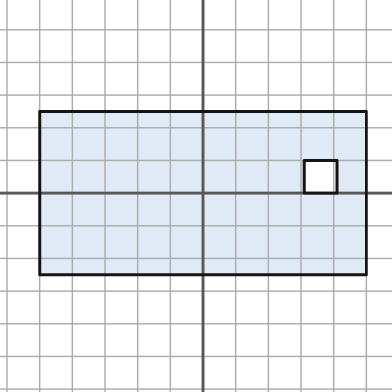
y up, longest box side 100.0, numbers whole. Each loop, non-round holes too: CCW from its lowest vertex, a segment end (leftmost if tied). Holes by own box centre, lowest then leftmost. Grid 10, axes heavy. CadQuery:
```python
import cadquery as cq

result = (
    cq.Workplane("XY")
    .moveTo(-50.0, -25.0)
    .lineTo(50.0, -25.0)
    .lineTo(50.0, 25.0)
    .lineTo(-50.0, 25.0)
    .close()
    .moveTo(31.0, 0.0)
    .lineTo(41.0, 0.0)
    .lineTo(41.0, 10.0)
    .lineTo(31.0, 10.0)
    .close()
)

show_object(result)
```